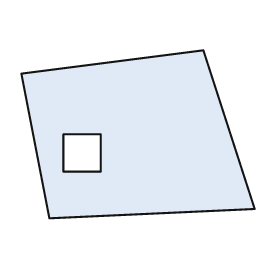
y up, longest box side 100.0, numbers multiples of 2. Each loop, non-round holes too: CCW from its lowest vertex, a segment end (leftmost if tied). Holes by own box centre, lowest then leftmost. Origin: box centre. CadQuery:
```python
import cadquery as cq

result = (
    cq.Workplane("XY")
    .moveTo(-38.0, -36.0)
    .lineTo(50.0, -32.0)
    .lineTo(28.0, 36.0)
    .lineTo(-50.0, 26.0)
    .close()
    .moveTo(-32.0, -16.0)
    .lineTo(-16.0, -16.0)
    .lineTo(-16.0, 0.0)
    .lineTo(-32.0, 0.0)
    .close()
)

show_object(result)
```